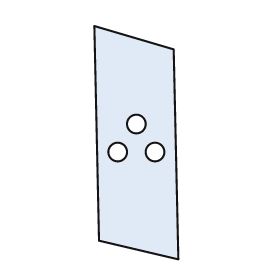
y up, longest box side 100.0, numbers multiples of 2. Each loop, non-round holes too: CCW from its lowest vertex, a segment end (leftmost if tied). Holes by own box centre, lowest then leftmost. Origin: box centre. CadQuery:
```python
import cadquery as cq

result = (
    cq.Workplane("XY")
    .moveTo(18.0, -50.0)
    .lineTo(16.0, 40.0)
    .lineTo(-18.0, 50.0)
    .lineTo(-16.0, -42.0)
    .close()
    .moveTo(-8.0, -4.0)
    .circle(4.0)
    .moveTo(8.0, -4.0)
    .circle(4.0)
    .moveTo(0.0, 8.0)
    .circle(4.0)
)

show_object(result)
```